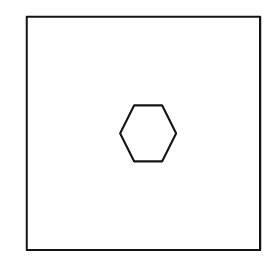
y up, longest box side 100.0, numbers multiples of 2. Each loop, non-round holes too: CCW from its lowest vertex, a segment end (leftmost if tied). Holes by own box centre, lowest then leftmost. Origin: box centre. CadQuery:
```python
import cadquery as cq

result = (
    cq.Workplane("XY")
    .moveTo(-50.0, -50.0)
    .lineTo(50.0, -50.0)
    .lineTo(50.0, 50.0)
    .lineTo(-50.0, 50.0)
    .close()
    .moveTo(-4.0, -12.0)
    .lineTo(8.0, -12.0)
    .lineTo(14.0, 0.0)
    .lineTo(8.0, 12.0)
    .lineTo(-4.0, 12.0)
    .lineTo(-10.0, 0.0)
    .close()
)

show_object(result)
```